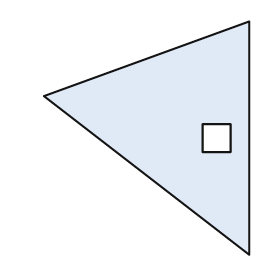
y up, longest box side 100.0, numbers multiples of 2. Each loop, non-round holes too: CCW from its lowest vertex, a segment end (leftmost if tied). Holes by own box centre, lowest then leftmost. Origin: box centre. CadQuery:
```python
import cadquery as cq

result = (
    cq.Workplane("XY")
    .moveTo(44.0, -50.0)
    .lineTo(44.0, 50.0)
    .lineTo(-44.0, 18.0)
    .close()
    .moveTo(24.0, -6.0)
    .lineTo(36.0, -6.0)
    .lineTo(36.0, 6.0)
    .lineTo(24.0, 6.0)
    .close()
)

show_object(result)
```